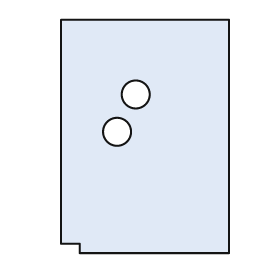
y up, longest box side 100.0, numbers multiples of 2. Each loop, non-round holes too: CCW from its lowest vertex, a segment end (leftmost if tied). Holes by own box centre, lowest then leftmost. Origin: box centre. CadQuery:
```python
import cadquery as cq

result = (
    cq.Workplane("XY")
    .moveTo(-28.0, -50.0)
    .lineTo(36.0, -50.0)
    .lineTo(36.0, 50.0)
    .lineTo(-36.0, 50.0)
    .lineTo(-36.0, -46.0)
    .lineTo(-28.0, -46.0)
    .close()
    .moveTo(-12.0, 2.0)
    .circle(6.0)
    .moveTo(-4.0, 18.0)
    .circle(6.0)
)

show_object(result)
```